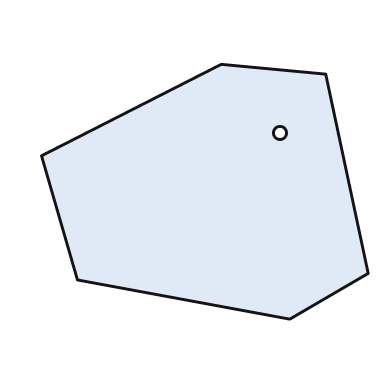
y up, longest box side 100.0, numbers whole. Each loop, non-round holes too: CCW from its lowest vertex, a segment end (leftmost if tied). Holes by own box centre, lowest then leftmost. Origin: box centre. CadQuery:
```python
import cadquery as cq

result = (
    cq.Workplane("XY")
    .moveTo(26.0, -39.0)
    .lineTo(50.0, -25.0)
    .lineTo(37.0, 36.0)
    .lineTo(5.0, 39.0)
    .lineTo(-50.0, 11.0)
    .lineTo(-39.0, -27.0)
    .close()
    .moveTo(23.0, 18.0)
    .circle(2.0)
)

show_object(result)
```